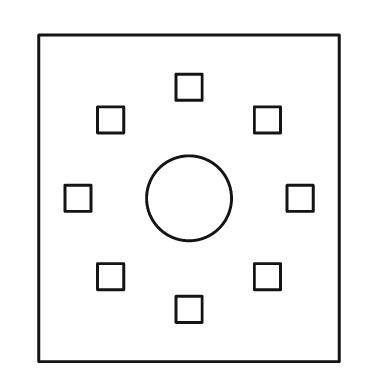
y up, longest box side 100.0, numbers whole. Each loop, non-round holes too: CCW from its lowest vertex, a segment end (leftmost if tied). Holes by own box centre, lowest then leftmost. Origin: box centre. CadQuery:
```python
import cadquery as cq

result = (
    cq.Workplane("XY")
    .moveTo(-46.0, -50.0)
    .lineTo(46.0, -50.0)
    .lineTo(46.0, 50.0)
    .lineTo(-46.0, 50.0)
    .close()
    .moveTo(-4.0, -38.0)
    .lineTo(4.0, -38.0)
    .lineTo(4.0, -30.0)
    .lineTo(-4.0, -30.0)
    .close()
    .moveTo(-28.0, -28.0)
    .lineTo(-20.0, -28.0)
    .lineTo(-20.0, -20.0)
    .lineTo(-28.0, -20.0)
    .close()
    .moveTo(20.0, -28.0)
    .lineTo(28.0, -28.0)
    .lineTo(28.0, -20.0)
    .lineTo(20.0, -20.0)
    .close()
    .moveTo(-38.0, -4.0)
    .lineTo(-30.0, -4.0)
    .lineTo(-30.0, 4.0)
    .lineTo(-38.0, 4.0)
    .close()
    .moveTo(0.0, 0.0)
    .circle(13.0)
    .moveTo(30.0, -4.0)
    .lineTo(38.0, -4.0)
    .lineTo(38.0, 4.0)
    .lineTo(30.0, 4.0)
    .close()
    .moveTo(-28.0, 20.0)
    .lineTo(-20.0, 20.0)
    .lineTo(-20.0, 28.0)
    .lineTo(-28.0, 28.0)
    .close()
    .moveTo(20.0, 20.0)
    .lineTo(28.0, 20.0)
    .lineTo(28.0, 28.0)
    .lineTo(20.0, 28.0)
    .close()
    .moveTo(-4.0, 30.0)
    .lineTo(4.0, 30.0)
    .lineTo(4.0, 38.0)
    .lineTo(-4.0, 38.0)
    .close()
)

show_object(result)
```